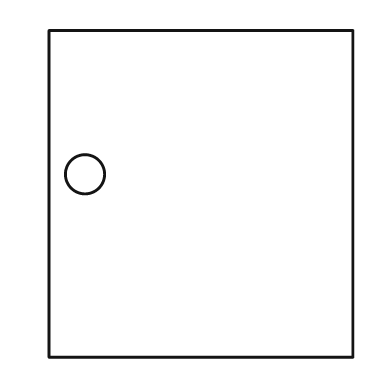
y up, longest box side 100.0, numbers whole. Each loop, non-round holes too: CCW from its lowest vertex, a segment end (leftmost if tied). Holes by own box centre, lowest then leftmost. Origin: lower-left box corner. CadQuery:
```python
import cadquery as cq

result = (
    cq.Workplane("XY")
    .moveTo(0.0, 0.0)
    .lineTo(93.0, 0.0)
    .lineTo(93.0, 100.0)
    .lineTo(0.0, 100.0)
    .close()
    .moveTo(11.0, 56.0)
    .circle(6.0)
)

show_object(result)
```